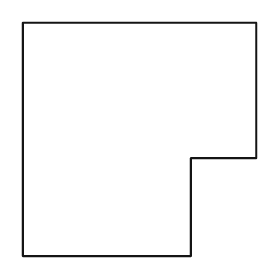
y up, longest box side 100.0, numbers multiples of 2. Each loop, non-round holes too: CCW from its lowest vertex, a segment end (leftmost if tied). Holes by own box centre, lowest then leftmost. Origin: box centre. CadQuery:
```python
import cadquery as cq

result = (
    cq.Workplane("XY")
    .moveTo(-50.0, -50.0)
    .lineTo(22.0, -50.0)
    .lineTo(22.0, -8.0)
    .lineTo(50.0, -8.0)
    .lineTo(50.0, 50.0)
    .lineTo(-50.0, 50.0)
    .close()
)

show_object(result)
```